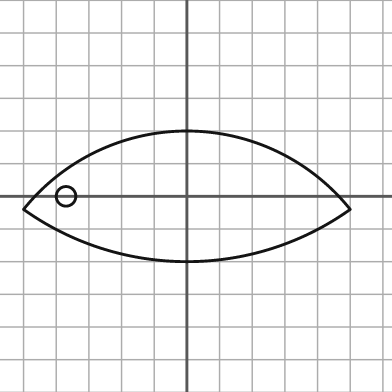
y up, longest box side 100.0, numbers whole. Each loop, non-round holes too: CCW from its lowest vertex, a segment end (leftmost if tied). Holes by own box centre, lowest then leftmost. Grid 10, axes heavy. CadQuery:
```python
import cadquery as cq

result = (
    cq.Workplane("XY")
    .moveTo(-50.0, -4.0)
    .threePointArc((0.0, -20.0), (50.0, -4.0))
    .threePointArc((0.0, 20.0), (-50.0, -4.0))
    .close()
    .moveTo(-37.0, 0.0)
    .circle(3.0)
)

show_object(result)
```